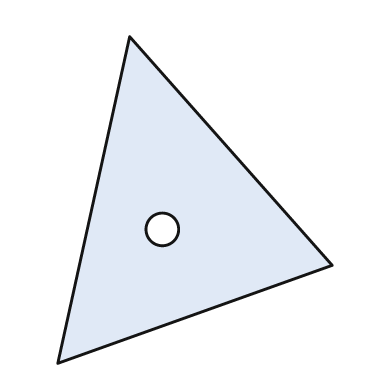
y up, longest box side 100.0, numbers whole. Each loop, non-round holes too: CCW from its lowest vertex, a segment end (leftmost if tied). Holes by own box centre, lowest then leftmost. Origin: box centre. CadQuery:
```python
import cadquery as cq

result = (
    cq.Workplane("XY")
    .moveTo(-42.0, -50.0)
    .lineTo(42.0, -20.0)
    .lineTo(-20.0, 50.0)
    .close()
    .moveTo(-10.0, -9.0)
    .circle(5.0)
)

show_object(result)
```